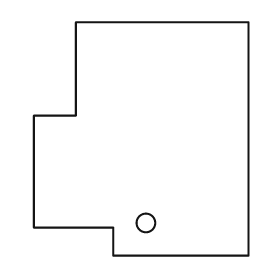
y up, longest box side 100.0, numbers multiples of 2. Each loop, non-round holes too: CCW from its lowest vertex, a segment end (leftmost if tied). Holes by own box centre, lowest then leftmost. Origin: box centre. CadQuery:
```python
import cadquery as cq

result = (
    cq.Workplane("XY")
    .moveTo(-12.0, -50.0)
    .lineTo(46.0, -50.0)
    .lineTo(46.0, 50.0)
    .lineTo(-28.0, 50.0)
    .lineTo(-28.0, 10.0)
    .lineTo(-46.0, 10.0)
    .lineTo(-46.0, -38.0)
    .lineTo(-12.0, -38.0)
    .close()
    .moveTo(2.0, -36.0)
    .circle(4.0)
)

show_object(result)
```